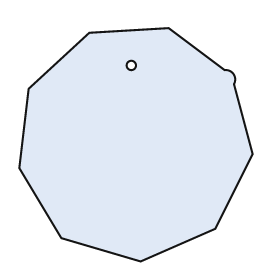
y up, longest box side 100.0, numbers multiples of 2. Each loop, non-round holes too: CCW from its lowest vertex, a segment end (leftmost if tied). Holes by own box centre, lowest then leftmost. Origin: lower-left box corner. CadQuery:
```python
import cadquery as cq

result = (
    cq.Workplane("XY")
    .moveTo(52.0, 0.0)
    .lineTo(84.0, 14.0)
    .lineTo(100.0, 46.0)
    .lineTo(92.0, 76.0)
    .threePointArc((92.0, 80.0), (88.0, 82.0))
    .lineTo(64.0, 100.0)
    .lineTo(30.0, 98.0)
    .lineTo(4.0, 74.0)
    .lineTo(0.0, 40.0)
    .lineTo(18.0, 10.0)
    .close()
    .moveTo(48.0, 84.0)
    .circle(2.0)
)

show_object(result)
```